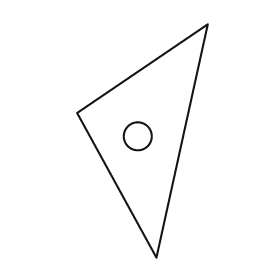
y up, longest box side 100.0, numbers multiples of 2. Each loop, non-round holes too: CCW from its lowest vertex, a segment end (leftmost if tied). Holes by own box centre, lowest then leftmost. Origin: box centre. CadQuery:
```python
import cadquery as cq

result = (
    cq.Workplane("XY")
    .moveTo(6.0, -50.0)
    .lineTo(28.0, 50.0)
    .lineTo(-28.0, 12.0)
    .close()
    .moveTo(-2.0, 2.0)
    .circle(6.0)
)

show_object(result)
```